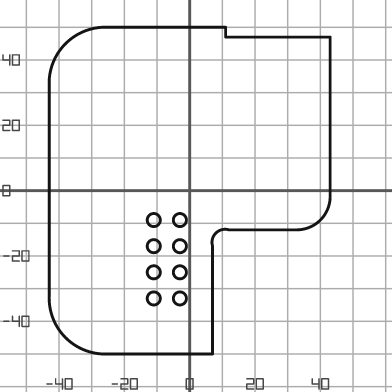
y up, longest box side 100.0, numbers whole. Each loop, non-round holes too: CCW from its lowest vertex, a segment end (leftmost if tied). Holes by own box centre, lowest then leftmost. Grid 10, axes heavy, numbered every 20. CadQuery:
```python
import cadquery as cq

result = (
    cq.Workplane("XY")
    .moveTo(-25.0, -50.0)
    .lineTo(7.0, -50.0)
    .lineTo(7.0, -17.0)
    .threePointArc((8.0, -13.0), (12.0, -12.0))
    .lineTo(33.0, -12.0)
    .threePointArc((40.0, -9.0), (43.0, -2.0))
    .lineTo(43.0, 47.0)
    .lineTo(11.0, 47.0)
    .lineTo(11.0, 50.0)
    .lineTo(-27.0, 50.0)
    .threePointArc((-38.0, 45.0), (-43.0, 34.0))
    .lineTo(-43.0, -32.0)
    .threePointArc((-38.0, -45.0), (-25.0, -50.0))
    .close()
    .moveTo(-11.0, -33.0)
    .circle(2.0)
    .moveTo(-3.0, -33.0)
    .circle(2.0)
    .moveTo(-11.0, -25.0)
    .circle(2.0)
    .moveTo(-3.0, -25.0)
    .circle(2.0)
    .moveTo(-11.0, -17.0)
    .circle(2.0)
    .moveTo(-3.0, -17.0)
    .circle(2.0)
    .moveTo(-11.0, -9.0)
    .circle(2.0)
    .moveTo(-3.0, -9.0)
    .circle(2.0)
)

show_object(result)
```